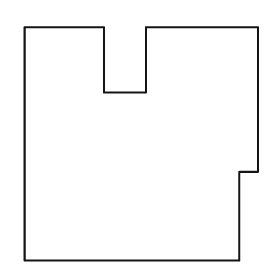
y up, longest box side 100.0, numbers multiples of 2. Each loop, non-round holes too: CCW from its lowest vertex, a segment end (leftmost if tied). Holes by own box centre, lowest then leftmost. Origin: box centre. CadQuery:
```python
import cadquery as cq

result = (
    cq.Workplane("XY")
    .moveTo(-50.0, -50.0)
    .lineTo(42.0, -50.0)
    .lineTo(42.0, -12.0)
    .lineTo(50.0, -12.0)
    .lineTo(50.0, 50.0)
    .lineTo(2.0, 50.0)
    .lineTo(2.0, 22.0)
    .lineTo(-16.0, 22.0)
    .lineTo(-16.0, 50.0)
    .lineTo(-50.0, 50.0)
    .close()
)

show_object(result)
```